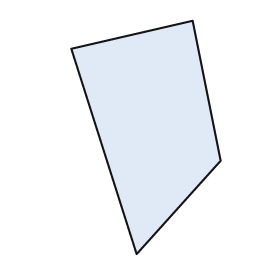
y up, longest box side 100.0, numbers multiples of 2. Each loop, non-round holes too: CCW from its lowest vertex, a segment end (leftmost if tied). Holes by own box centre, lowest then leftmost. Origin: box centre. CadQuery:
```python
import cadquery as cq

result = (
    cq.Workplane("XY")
    .moveTo(-4.0, -50.0)
    .lineTo(32.0, -10.0)
    .lineTo(20.0, 50.0)
    .lineTo(-32.0, 38.0)
    .close()
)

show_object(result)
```